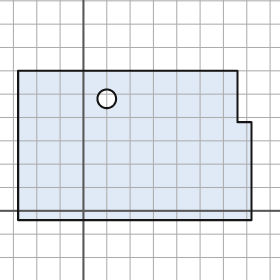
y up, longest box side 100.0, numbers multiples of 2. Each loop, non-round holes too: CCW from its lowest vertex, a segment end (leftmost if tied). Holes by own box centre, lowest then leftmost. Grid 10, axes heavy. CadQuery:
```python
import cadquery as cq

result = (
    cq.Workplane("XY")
    .moveTo(-28.0, -4.0)
    .lineTo(72.0, -4.0)
    .lineTo(72.0, 38.0)
    .lineTo(66.0, 38.0)
    .lineTo(66.0, 60.0)
    .lineTo(-28.0, 60.0)
    .close()
    .moveTo(10.0, 48.0)
    .circle(4.0)
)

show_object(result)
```